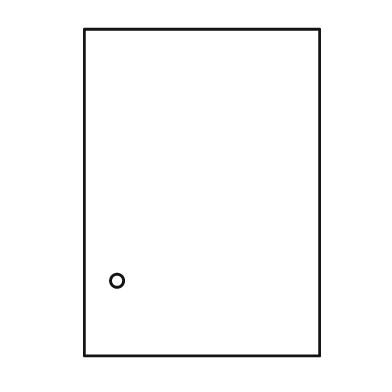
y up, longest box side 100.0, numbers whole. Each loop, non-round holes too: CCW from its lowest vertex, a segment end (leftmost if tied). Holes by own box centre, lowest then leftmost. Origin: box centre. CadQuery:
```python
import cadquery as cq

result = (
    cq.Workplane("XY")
    .moveTo(-36.0, -50.0)
    .lineTo(36.0, -50.0)
    .lineTo(36.0, 50.0)
    .lineTo(-36.0, 50.0)
    .close()
    .moveTo(-26.0, -27.0)
    .circle(2.0)
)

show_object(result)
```